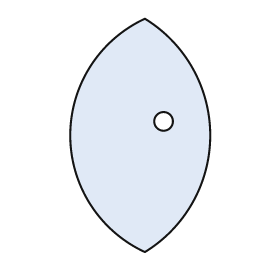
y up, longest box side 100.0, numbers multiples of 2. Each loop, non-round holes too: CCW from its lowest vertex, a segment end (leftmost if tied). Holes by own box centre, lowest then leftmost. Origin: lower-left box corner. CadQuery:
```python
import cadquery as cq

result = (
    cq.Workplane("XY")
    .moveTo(32.0, 0.0)
    .threePointArc((60.0, 50.0), (32.0, 100.0))
    .threePointArc((0.0, 50.0), (32.0, 0.0))
    .close()
    .moveTo(40.0, 56.0)
    .circle(4.0)
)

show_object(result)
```